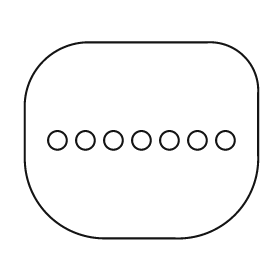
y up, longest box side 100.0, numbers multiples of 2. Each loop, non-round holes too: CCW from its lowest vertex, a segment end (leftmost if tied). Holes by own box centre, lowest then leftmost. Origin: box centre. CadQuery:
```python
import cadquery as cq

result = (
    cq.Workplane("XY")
    .moveTo(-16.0, -42.0)
    .lineTo(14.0, -42.0)
    .threePointArc((40.0, -32.0), (50.0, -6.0))
    .lineTo(50.0, 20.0)
    .threePointArc((44.0, 36.0), (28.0, 42.0))
    .lineTo(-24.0, 42.0)
    .threePointArc((-42.0, 34.0), (-50.0, 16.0))
    .lineTo(-50.0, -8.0)
    .threePointArc((-40.0, -32.0), (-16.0, -42.0))
    .close()
    .moveTo(-36.0, 0.0)
    .circle(4.0)
    .moveTo(-24.0, 0.0)
    .circle(4.0)
    .moveTo(-12.0, 0.0)
    .circle(4.0)
    .moveTo(0.0, 0.0)
    .circle(4.0)
    .moveTo(12.0, 0.0)
    .circle(4.0)
    .moveTo(24.0, 0.0)
    .circle(4.0)
    .moveTo(36.0, 0.0)
    .circle(4.0)
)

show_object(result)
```